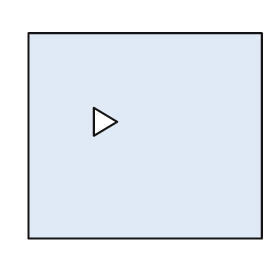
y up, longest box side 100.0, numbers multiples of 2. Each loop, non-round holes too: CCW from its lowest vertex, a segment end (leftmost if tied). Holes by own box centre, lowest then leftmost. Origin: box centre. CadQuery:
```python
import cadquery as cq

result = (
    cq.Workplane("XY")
    .moveTo(-50.0, -44.0)
    .lineTo(50.0, -44.0)
    .lineTo(50.0, 44.0)
    .lineTo(-50.0, 44.0)
    .close()
    .moveTo(-22.0, 0.0)
    .lineTo(-12.0, 6.0)
    .lineTo(-22.0, 12.0)
    .close()
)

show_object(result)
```